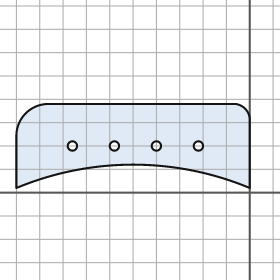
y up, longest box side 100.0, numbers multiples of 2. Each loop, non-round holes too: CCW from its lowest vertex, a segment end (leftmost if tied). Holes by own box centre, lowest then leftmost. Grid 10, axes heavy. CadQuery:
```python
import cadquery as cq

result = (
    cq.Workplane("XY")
    .moveTo(-100.0, 2.0)
    .threePointArc((-50.0, 12.0), (0.0, 2.0))
    .lineTo(0.0, 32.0)
    .threePointArc((-2.0, 36.0), (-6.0, 38.0))
    .lineTo(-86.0, 38.0)
    .threePointArc((-96.0, 34.0), (-100.0, 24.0))
    .close()
    .moveTo(-76.0, 20.0)
    .circle(2.0)
    .moveTo(-58.0, 20.0)
    .circle(2.0)
    .moveTo(-40.0, 20.0)
    .circle(2.0)
    .moveTo(-22.0, 20.0)
    .circle(2.0)
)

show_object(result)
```